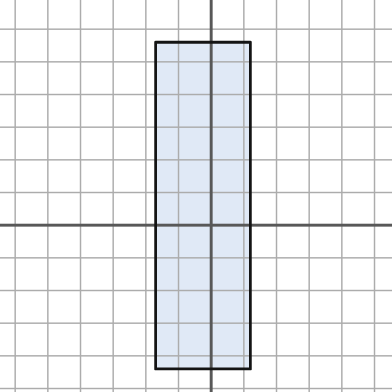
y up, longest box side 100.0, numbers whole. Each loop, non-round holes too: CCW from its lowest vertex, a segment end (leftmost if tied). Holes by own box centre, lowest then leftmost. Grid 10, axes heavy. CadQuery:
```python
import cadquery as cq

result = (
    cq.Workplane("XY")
    .moveTo(-17.0, -44.0)
    .lineTo(12.0, -44.0)
    .lineTo(12.0, 56.0)
    .lineTo(-17.0, 56.0)
    .close()
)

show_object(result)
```